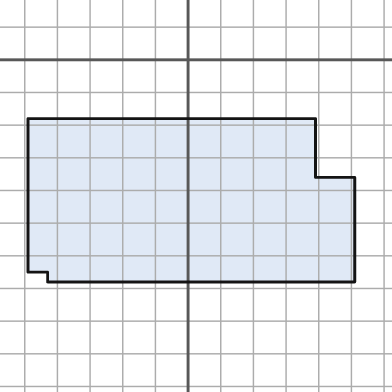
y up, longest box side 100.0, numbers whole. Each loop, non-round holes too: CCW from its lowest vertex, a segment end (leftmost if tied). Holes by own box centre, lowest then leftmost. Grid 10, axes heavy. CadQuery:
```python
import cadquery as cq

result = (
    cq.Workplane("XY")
    .moveTo(-43.0, -68.0)
    .lineTo(51.0, -68.0)
    .lineTo(51.0, -36.0)
    .lineTo(39.0, -36.0)
    .lineTo(39.0, -18.0)
    .lineTo(-49.0, -18.0)
    .lineTo(-49.0, -65.0)
    .lineTo(-43.0, -65.0)
    .close()
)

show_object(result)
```